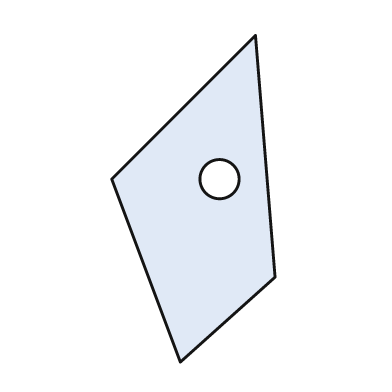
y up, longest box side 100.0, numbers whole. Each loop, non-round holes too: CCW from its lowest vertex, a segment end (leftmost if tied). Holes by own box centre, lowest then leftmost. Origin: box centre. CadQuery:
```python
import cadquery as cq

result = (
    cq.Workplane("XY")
    .moveTo(-4.0, -50.0)
    .lineTo(25.0, -24.0)
    .lineTo(19.0, 50.0)
    .lineTo(-25.0, 6.0)
    .close()
    .moveTo(8.0, 6.0)
    .circle(6.0)
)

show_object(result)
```